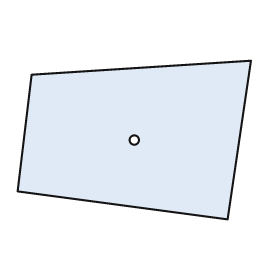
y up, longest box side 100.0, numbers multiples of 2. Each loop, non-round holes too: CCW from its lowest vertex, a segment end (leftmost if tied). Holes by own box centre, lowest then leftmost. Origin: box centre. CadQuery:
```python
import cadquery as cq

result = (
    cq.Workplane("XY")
    .moveTo(40.0, -34.0)
    .lineTo(50.0, 34.0)
    .lineTo(-44.0, 28.0)
    .lineTo(-50.0, -22.0)
    .close()
    .moveTo(0.0, 0.0)
    .circle(2.0)
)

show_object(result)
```